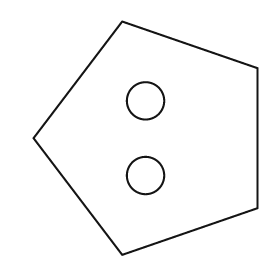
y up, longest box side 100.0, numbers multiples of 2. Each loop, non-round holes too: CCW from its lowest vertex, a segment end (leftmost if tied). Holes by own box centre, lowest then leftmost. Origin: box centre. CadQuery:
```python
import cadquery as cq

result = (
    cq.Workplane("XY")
    .moveTo(-10.0, -50.0)
    .lineTo(48.0, -30.0)
    .lineTo(48.0, 30.0)
    .lineTo(-10.0, 50.0)
    .lineTo(-48.0, 0.0)
    .close()
    .moveTo(0.0, -16.0)
    .circle(8.0)
    .moveTo(0.0, 16.0)
    .circle(8.0)
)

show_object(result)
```